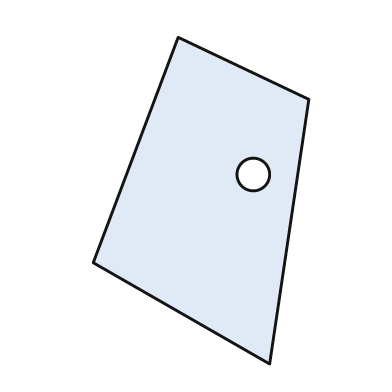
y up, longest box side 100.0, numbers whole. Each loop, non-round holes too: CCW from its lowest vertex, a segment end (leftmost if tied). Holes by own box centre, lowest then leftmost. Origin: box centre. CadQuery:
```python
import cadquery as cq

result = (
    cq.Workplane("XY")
    .moveTo(21.0, -50.0)
    .lineTo(33.0, 31.0)
    .lineTo(-7.0, 50.0)
    .lineTo(-33.0, -19.0)
    .close()
    .moveTo(16.0, 8.0)
    .circle(5.0)
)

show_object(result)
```